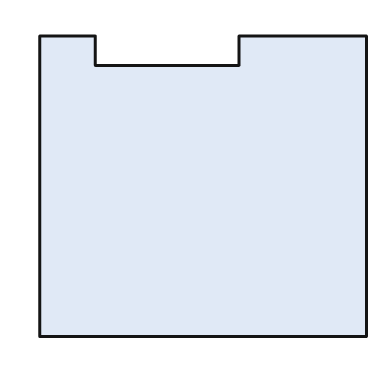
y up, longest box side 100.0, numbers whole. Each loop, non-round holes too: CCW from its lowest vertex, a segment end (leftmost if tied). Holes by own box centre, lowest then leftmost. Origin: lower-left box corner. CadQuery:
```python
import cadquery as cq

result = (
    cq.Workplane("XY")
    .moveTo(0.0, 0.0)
    .lineTo(100.0, 0.0)
    .lineTo(100.0, 92.0)
    .lineTo(61.0, 92.0)
    .lineTo(61.0, 83.0)
    .lineTo(17.0, 83.0)
    .lineTo(17.0, 92.0)
    .lineTo(0.0, 92.0)
    .close()
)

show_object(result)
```